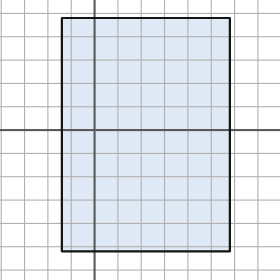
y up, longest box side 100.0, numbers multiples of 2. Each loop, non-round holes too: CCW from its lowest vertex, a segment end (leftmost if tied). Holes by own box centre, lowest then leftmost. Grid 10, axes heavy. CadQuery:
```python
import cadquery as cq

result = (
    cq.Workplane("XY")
    .moveTo(-14.0, -52.0)
    .lineTo(58.0, -52.0)
    .lineTo(58.0, 48.0)
    .lineTo(-14.0, 48.0)
    .close()
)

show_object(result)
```